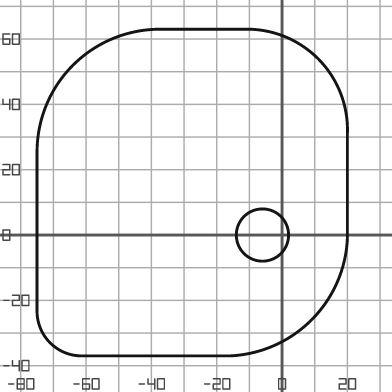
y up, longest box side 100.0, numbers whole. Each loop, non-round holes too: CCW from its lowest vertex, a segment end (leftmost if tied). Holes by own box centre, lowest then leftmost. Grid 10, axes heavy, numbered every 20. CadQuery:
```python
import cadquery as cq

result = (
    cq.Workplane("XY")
    .moveTo(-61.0, -37.0)
    .lineTo(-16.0, -37.0)
    .threePointArc((9.0, -26.0), (20.0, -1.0))
    .lineTo(20.0, 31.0)
    .threePointArc((11.0, 54.0), (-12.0, 63.0))
    .lineTo(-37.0, 63.0)
    .threePointArc((-64.0, 52.0), (-75.0, 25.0))
    .lineTo(-75.0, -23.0)
    .threePointArc((-71.0, -33.0), (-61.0, -37.0))
    .close()
    .moveTo(-6.0, 0.0)
    .circle(8.0)
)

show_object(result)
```